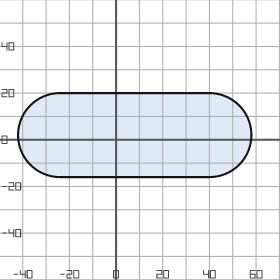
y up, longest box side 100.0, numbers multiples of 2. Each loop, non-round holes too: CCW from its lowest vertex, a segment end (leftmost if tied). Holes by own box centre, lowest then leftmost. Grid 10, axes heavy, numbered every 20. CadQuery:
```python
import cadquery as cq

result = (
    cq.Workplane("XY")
    .moveTo(-24.0, -16.0)
    .lineTo(40.0, -16.0)
    .threePointArc((58.0, 2.0), (40.0, 20.0))
    .lineTo(-24.0, 20.0)
    .threePointArc((-42.0, 2.0), (-24.0, -16.0))
    .close()
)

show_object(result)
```